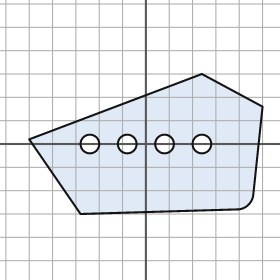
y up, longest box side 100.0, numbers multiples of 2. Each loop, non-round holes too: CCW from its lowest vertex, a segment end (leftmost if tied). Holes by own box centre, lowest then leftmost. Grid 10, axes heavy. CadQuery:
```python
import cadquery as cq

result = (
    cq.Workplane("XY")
    .moveTo(-28.0, -30.0)
    .lineTo(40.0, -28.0)
    .threePointArc((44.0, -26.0), (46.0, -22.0))
    .lineTo(50.0, 16.0)
    .lineTo(24.0, 30.0)
    .lineTo(-50.0, 2.0)
    .close()
    .moveTo(-24.0, 0.0)
    .circle(4.0)
    .moveTo(-8.0, 0.0)
    .circle(4.0)
    .moveTo(8.0, 0.0)
    .circle(4.0)
    .moveTo(24.0, 0.0)
    .circle(4.0)
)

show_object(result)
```